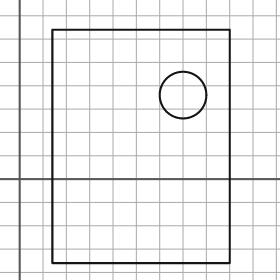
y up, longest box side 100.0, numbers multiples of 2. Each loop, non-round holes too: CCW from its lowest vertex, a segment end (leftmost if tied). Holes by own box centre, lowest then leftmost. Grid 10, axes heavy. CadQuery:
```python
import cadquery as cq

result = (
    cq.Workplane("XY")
    .moveTo(14.0, -36.0)
    .lineTo(90.0, -36.0)
    .lineTo(90.0, 64.0)
    .lineTo(14.0, 64.0)
    .close()
    .moveTo(70.0, 36.0)
    .circle(10.0)
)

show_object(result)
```